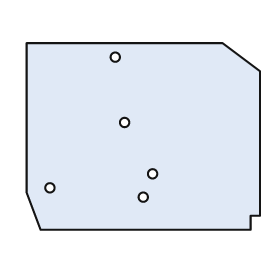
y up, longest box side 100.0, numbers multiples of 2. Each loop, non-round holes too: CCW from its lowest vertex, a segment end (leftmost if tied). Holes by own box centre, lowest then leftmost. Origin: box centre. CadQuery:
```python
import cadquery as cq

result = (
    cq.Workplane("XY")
    .moveTo(-44.0, -40.0)
    .lineTo(46.0, -40.0)
    .lineTo(46.0, -34.0)
    .lineTo(50.0, -34.0)
    .lineTo(50.0, 28.0)
    .lineTo(34.0, 40.0)
    .lineTo(-50.0, 40.0)
    .lineTo(-50.0, -24.0)
    .close()
    .moveTo(0.0, -26.0)
    .circle(2.0)
    .moveTo(-40.0, -22.0)
    .circle(2.0)
    .moveTo(4.0, -16.0)
    .circle(2.0)
    .moveTo(-8.0, 6.0)
    .circle(2.0)
    .moveTo(-12.0, 34.0)
    .circle(2.0)
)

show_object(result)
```